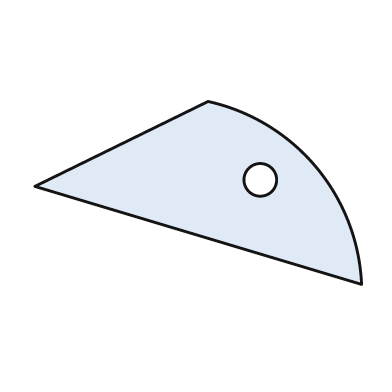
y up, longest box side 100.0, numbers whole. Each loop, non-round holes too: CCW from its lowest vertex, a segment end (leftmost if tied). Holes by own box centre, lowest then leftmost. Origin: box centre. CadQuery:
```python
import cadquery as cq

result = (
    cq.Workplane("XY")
    .moveTo(50.0, -28.0)
    .threePointArc((36.0, 8.0), (3.0, 28.0))
    .lineTo(-50.0, 2.0)
    .close()
    .moveTo(19.0, 4.0)
    .circle(5.0)
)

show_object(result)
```